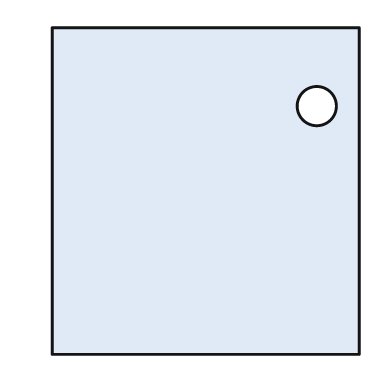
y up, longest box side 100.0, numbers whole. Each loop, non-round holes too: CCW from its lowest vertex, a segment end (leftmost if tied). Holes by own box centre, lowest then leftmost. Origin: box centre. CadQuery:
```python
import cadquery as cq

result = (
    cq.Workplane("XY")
    .moveTo(-47.0, -50.0)
    .lineTo(47.0, -50.0)
    .lineTo(47.0, 50.0)
    .lineTo(-47.0, 50.0)
    .close()
    .moveTo(34.0, 26.0)
    .circle(6.0)
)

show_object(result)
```